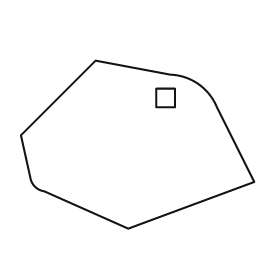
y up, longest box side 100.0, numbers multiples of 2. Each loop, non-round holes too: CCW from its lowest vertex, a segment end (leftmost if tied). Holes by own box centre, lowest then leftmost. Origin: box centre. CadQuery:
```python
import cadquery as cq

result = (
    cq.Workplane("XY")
    .moveTo(-4.0, -36.0)
    .lineTo(50.0, -16.0)
    .lineTo(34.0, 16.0)
    .threePointArc((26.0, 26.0), (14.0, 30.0))
    .lineTo(-18.0, 36.0)
    .lineTo(-50.0, 4.0)
    .lineTo(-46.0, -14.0)
    .threePointArc((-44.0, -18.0), (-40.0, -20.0))
    .close()
    .moveTo(8.0, 16.0)
    .lineTo(16.0, 16.0)
    .lineTo(16.0, 24.0)
    .lineTo(8.0, 24.0)
    .close()
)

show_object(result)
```